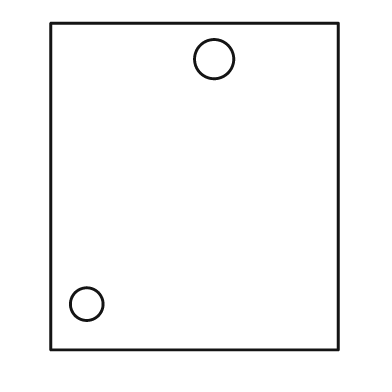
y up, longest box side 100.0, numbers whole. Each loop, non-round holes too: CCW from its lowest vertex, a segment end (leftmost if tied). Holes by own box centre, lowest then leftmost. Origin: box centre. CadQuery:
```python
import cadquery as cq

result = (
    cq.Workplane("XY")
    .moveTo(-44.0, -50.0)
    .lineTo(44.0, -50.0)
    .lineTo(44.0, 50.0)
    .lineTo(-44.0, 50.0)
    .close()
    .moveTo(-33.0, -36.0)
    .circle(5.0)
    .moveTo(6.0, 39.0)
    .circle(6.0)
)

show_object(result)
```